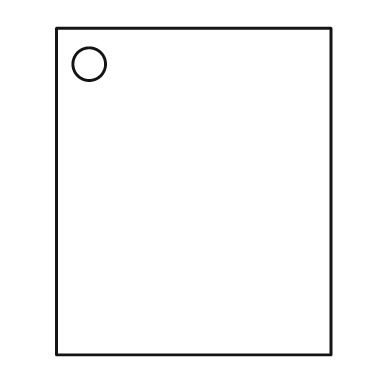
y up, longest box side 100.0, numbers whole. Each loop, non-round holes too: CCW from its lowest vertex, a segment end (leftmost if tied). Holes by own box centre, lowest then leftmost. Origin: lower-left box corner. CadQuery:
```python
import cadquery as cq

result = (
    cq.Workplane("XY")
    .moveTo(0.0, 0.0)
    .lineTo(84.0, 0.0)
    .lineTo(84.0, 100.0)
    .lineTo(0.0, 100.0)
    .close()
    .moveTo(10.0, 89.0)
    .circle(5.0)
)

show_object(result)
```